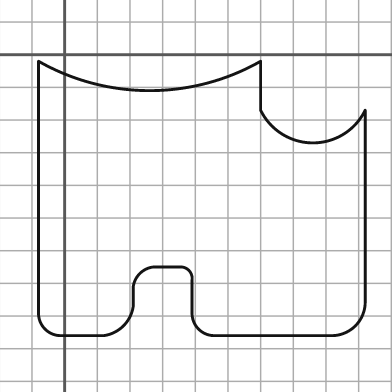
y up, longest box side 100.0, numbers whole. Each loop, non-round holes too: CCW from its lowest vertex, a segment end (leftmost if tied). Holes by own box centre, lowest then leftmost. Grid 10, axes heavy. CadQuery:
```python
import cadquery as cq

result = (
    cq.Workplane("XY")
    .moveTo(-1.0, -86.0)
    .lineTo(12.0, -86.0)
    .threePointArc((18.0, -83.0), (21.0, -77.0))
    .lineTo(21.0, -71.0)
    .threePointArc((23.0, -67.0), (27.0, -65.0))
    .lineTo(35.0, -65.0)
    .threePointArc((38.0, -66.0), (39.0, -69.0))
    .lineTo(39.0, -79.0)
    .threePointArc((41.0, -84.0), (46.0, -86.0))
    .lineTo(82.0, -86.0)
    .threePointArc((89.0, -83.0), (92.0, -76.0))
    .lineTo(92.0, -17.0)
    .threePointArc((76.0, -27.0), (60.0, -17.0))
    .lineTo(60.0, -2.0)
    .threePointArc((26.0, -11.0), (-8.0, -2.0))
    .lineTo(-8.0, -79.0)
    .threePointArc((-6.0, -84.0), (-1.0, -86.0))
    .close()
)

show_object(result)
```